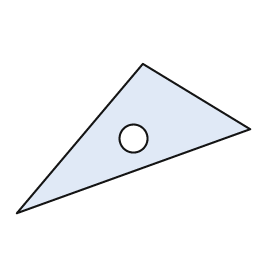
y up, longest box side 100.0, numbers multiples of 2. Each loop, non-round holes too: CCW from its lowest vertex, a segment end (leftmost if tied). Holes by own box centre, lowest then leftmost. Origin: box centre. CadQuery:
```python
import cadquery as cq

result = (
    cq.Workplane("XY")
    .moveTo(-50.0, -32.0)
    .lineTo(50.0, 4.0)
    .lineTo(4.0, 32.0)
    .close()
    .moveTo(0.0, 0.0)
    .circle(6.0)
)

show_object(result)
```